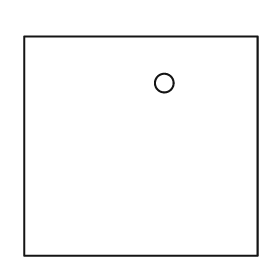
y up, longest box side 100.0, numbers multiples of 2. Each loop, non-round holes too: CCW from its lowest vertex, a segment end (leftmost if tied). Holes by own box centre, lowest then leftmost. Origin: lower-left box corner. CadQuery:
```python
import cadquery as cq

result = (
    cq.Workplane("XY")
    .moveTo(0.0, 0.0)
    .lineTo(100.0, 0.0)
    .lineTo(100.0, 94.0)
    .lineTo(0.0, 94.0)
    .close()
    .moveTo(60.0, 74.0)
    .circle(4.0)
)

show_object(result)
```